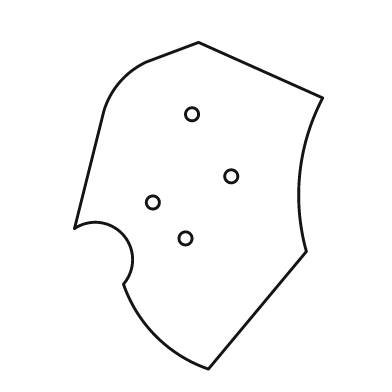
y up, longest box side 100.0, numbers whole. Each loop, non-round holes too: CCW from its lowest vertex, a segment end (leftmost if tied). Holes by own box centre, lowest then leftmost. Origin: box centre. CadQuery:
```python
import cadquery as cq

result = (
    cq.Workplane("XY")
    .moveTo(3.0, -50.0)
    .lineTo(33.0, -14.0)
    .threePointArc((31.0, 10.0), (38.0, 33.0))
    .lineTo(0.0, 50.0)
    .lineTo(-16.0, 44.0)
    .threePointArc((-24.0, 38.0), (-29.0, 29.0))
    .lineTo(-38.0, -7.0)
    .threePointArc((-23.0, -9.0), (-23.0, -24.0))
    .threePointArc((-13.0, -40.0), (3.0, -50.0))
    .close()
    .moveTo(-4.0, -10.0)
    .circle(2.0)
    .moveTo(-14.0, 1.0)
    .circle(2.0)
    .moveTo(10.0, 9.0)
    .circle(2.0)
    .moveTo(-2.0, 28.0)
    .circle(2.0)
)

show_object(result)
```